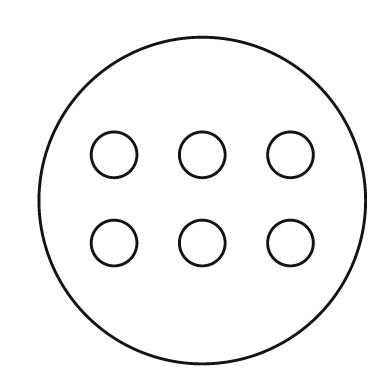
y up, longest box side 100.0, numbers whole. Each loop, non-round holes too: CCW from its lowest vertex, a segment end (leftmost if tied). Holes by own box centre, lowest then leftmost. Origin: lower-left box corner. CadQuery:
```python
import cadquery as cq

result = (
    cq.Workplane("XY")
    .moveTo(50.0, 50.0)
    .circle(50.0)
    .moveTo(23.0, 37.0)
    .circle(7.0)
    .moveTo(50.0, 37.0)
    .circle(7.0)
    .moveTo(77.0, 37.0)
    .circle(7.0)
    .moveTo(23.0, 64.0)
    .circle(7.0)
    .moveTo(50.0, 64.0)
    .circle(7.0)
    .moveTo(77.0, 64.0)
    .circle(7.0)
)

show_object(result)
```